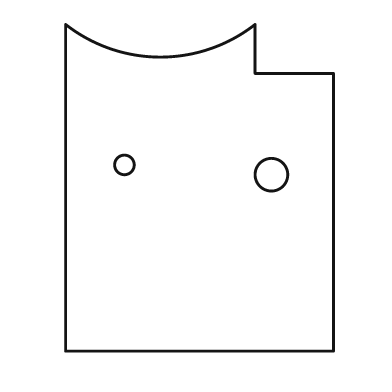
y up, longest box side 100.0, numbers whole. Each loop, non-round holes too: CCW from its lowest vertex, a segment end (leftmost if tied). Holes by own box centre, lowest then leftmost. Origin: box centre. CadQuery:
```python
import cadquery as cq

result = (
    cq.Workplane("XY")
    .moveTo(-41.0, -50.0)
    .lineTo(41.0, -50.0)
    .lineTo(41.0, 35.0)
    .lineTo(17.0, 35.0)
    .lineTo(17.0, 50.0)
    .threePointArc((-12.0, 40.0), (-41.0, 50.0))
    .close()
    .moveTo(22.0, 4.0)
    .circle(5.0)
    .moveTo(-23.0, 7.0)
    .circle(3.0)
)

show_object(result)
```